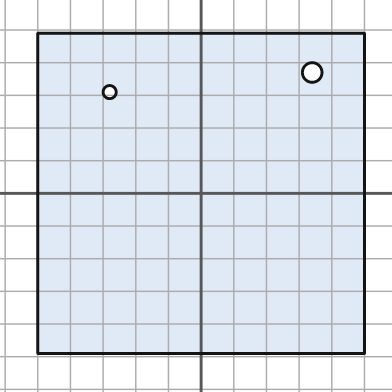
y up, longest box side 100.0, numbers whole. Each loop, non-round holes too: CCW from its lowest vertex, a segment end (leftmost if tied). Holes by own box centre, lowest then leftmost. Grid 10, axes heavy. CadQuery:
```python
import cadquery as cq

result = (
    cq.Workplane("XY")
    .moveTo(-50.0, -49.0)
    .lineTo(50.0, -49.0)
    .lineTo(50.0, 49.0)
    .lineTo(-50.0, 49.0)
    .close()
    .moveTo(-28.0, 31.0)
    .circle(2.0)
    .moveTo(34.0, 37.0)
    .circle(3.0)
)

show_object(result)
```